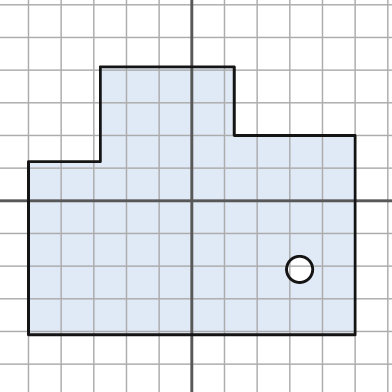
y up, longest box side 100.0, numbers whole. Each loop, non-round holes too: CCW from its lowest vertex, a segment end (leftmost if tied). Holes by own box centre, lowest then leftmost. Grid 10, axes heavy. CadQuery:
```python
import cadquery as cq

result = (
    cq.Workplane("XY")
    .moveTo(-50.0, -41.0)
    .lineTo(50.0, -41.0)
    .lineTo(50.0, 20.0)
    .lineTo(13.0, 20.0)
    .lineTo(13.0, 41.0)
    .lineTo(-28.0, 41.0)
    .lineTo(-28.0, 12.0)
    .lineTo(-50.0, 12.0)
    .close()
    .moveTo(33.0, -21.0)
    .circle(4.0)
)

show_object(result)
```